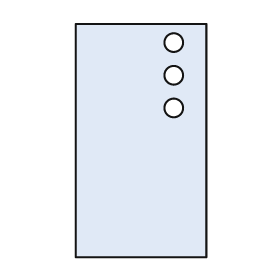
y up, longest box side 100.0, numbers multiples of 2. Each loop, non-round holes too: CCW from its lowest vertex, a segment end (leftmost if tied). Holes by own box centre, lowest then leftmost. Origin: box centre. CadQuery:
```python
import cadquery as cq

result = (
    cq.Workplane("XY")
    .moveTo(-28.0, -50.0)
    .lineTo(28.0, -50.0)
    .lineTo(28.0, 50.0)
    .lineTo(-28.0, 50.0)
    .close()
    .moveTo(14.0, 14.0)
    .circle(4.0)
    .moveTo(14.0, 28.0)
    .circle(4.0)
    .moveTo(14.0, 42.0)
    .circle(4.0)
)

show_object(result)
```